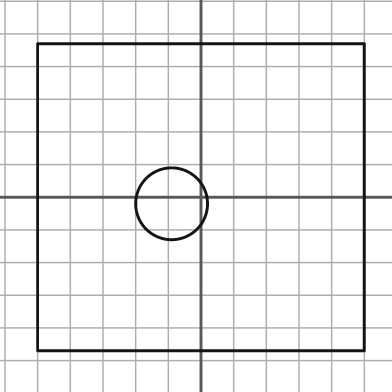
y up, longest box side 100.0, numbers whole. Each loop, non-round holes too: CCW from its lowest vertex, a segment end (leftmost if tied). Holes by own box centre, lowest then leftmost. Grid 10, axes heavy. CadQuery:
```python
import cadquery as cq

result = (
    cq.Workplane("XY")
    .moveTo(-50.0, -47.0)
    .lineTo(50.0, -47.0)
    .lineTo(50.0, 47.0)
    .lineTo(-50.0, 47.0)
    .close()
    .moveTo(-9.0, -2.0)
    .circle(11.0)
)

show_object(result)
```